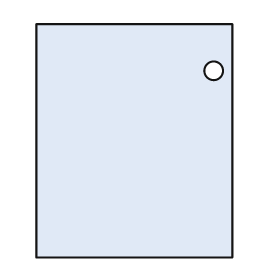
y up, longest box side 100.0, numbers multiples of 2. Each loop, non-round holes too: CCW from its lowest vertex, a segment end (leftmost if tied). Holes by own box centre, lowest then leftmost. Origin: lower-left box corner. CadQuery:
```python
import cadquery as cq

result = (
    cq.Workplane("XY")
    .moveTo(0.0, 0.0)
    .lineTo(84.0, 0.0)
    .lineTo(84.0, 100.0)
    .lineTo(0.0, 100.0)
    .close()
    .moveTo(76.0, 80.0)
    .circle(4.0)
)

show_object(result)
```